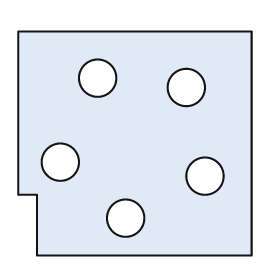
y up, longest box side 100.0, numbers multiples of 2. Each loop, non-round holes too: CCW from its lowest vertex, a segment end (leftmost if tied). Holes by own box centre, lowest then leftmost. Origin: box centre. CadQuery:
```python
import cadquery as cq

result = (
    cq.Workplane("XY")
    .moveTo(-42.0, -48.0)
    .lineTo(50.0, -48.0)
    .lineTo(50.0, 48.0)
    .lineTo(-50.0, 48.0)
    .lineTo(-50.0, -22.0)
    .lineTo(-42.0, -22.0)
    .close()
    .moveTo(-4.0, -32.0)
    .circle(8.0)
    .moveTo(30.0, -14.0)
    .circle(8.0)
    .moveTo(-32.0, -8.0)
    .circle(8.0)
    .moveTo(22.0, 24.0)
    .circle(8.0)
    .moveTo(-16.0, 28.0)
    .circle(8.0)
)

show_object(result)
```